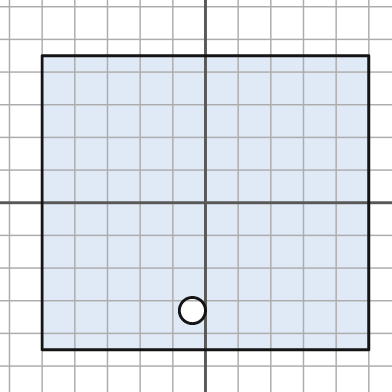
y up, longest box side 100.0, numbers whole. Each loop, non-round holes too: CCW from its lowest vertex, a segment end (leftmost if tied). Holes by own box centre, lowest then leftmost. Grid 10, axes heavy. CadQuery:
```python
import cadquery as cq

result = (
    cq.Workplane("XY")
    .moveTo(-50.0, -45.0)
    .lineTo(50.0, -45.0)
    .lineTo(50.0, 45.0)
    .lineTo(-50.0, 45.0)
    .close()
    .moveTo(-4.0, -33.0)
    .circle(4.0)
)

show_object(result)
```